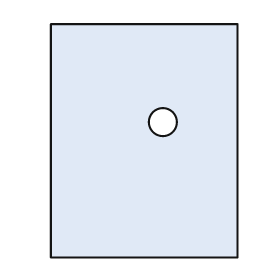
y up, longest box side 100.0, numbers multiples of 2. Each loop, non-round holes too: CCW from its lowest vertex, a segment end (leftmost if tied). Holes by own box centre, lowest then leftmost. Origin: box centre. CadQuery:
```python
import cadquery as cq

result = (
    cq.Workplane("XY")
    .moveTo(-40.0, -50.0)
    .lineTo(40.0, -50.0)
    .lineTo(40.0, 50.0)
    .lineTo(-40.0, 50.0)
    .close()
    .moveTo(8.0, 8.0)
    .circle(6.0)
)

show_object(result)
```